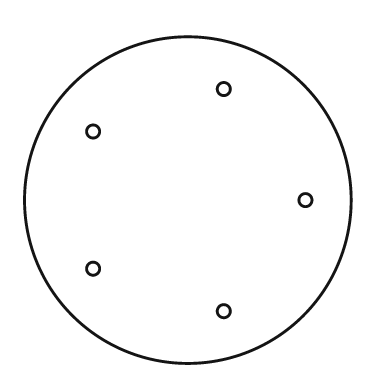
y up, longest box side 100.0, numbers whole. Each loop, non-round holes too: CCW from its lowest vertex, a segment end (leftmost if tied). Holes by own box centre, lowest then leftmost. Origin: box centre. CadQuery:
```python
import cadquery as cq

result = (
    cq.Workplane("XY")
    .moveTo(0.0, 0.0)
    .circle(50.0)
    .moveTo(11.0, -34.0)
    .circle(2.0)
    .moveTo(-29.0, -21.0)
    .circle(2.0)
    .moveTo(36.0, 0.0)
    .circle(2.0)
    .moveTo(-29.0, 21.0)
    .circle(2.0)
    .moveTo(11.0, 34.0)
    .circle(2.0)
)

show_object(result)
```